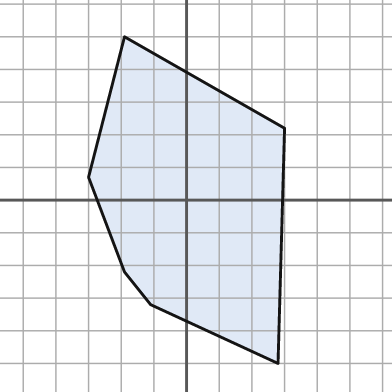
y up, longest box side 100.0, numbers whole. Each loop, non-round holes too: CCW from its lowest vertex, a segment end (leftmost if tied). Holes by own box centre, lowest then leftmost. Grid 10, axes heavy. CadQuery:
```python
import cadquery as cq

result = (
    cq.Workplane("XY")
    .moveTo(28.0, -50.0)
    .lineTo(30.0, 22.0)
    .lineTo(-19.0, 50.0)
    .lineTo(-30.0, 7.0)
    .lineTo(-19.0, -22.0)
    .lineTo(-11.0, -32.0)
    .close()
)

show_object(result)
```